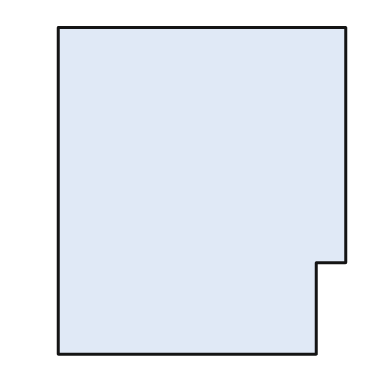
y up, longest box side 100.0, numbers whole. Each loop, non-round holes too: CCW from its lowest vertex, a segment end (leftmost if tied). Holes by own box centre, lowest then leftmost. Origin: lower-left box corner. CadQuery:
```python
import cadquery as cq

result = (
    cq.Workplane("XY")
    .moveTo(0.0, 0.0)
    .lineTo(79.0, 0.0)
    .lineTo(79.0, 28.0)
    .lineTo(88.0, 28.0)
    .lineTo(88.0, 100.0)
    .lineTo(0.0, 100.0)
    .close()
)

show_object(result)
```